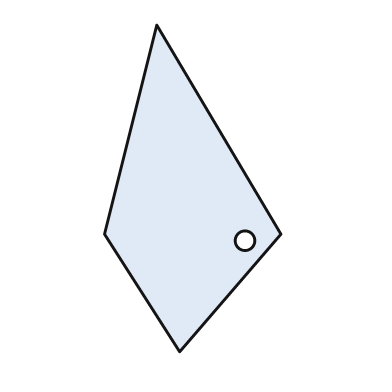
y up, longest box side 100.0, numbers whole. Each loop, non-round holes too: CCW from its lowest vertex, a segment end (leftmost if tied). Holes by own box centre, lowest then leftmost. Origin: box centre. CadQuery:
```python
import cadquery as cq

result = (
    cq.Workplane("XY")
    .moveTo(-4.0, -50.0)
    .lineTo(27.0, -14.0)
    .lineTo(-11.0, 50.0)
    .lineTo(-27.0, -14.0)
    .close()
    .moveTo(16.0, -16.0)
    .circle(3.0)
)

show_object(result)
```